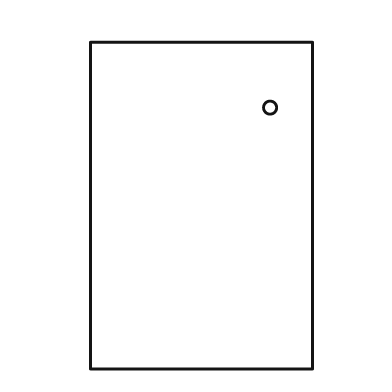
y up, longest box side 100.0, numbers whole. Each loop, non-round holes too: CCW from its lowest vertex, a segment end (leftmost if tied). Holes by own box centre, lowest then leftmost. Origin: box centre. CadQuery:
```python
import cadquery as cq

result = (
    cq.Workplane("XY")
    .moveTo(-34.0, -50.0)
    .lineTo(34.0, -50.0)
    .lineTo(34.0, 50.0)
    .lineTo(-34.0, 50.0)
    .close()
    .moveTo(21.0, 30.0)
    .circle(2.0)
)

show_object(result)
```